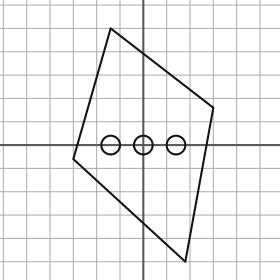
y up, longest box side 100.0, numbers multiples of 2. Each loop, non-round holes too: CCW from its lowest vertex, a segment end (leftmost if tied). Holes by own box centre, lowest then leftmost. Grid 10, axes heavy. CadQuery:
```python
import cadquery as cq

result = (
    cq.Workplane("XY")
    .moveTo(18.0, -50.0)
    .lineTo(30.0, 16.0)
    .lineTo(-14.0, 50.0)
    .lineTo(-30.0, -6.0)
    .close()
    .moveTo(-14.0, 0.0)
    .circle(4.0)
    .moveTo(0.0, 0.0)
    .circle(4.0)
    .moveTo(14.0, 0.0)
    .circle(4.0)
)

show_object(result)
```